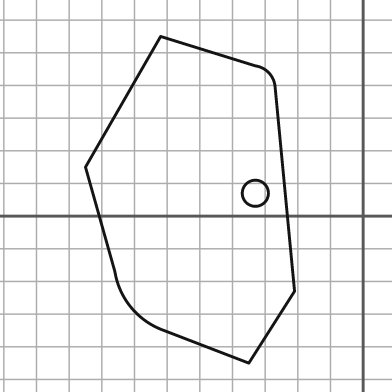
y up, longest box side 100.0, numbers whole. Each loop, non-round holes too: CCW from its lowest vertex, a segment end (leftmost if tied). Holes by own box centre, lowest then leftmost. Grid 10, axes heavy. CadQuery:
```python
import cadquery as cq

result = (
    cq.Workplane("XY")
    .moveTo(-35.0, -45.0)
    .lineTo(-21.0, -23.0)
    .lineTo(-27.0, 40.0)
    .threePointArc((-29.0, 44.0), (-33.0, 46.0))
    .lineTo(-62.0, 55.0)
    .lineTo(-85.0, 15.0)
    .lineTo(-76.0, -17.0)
    .threePointArc((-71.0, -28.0), (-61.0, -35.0))
    .close()
    .moveTo(-33.0, 7.0)
    .circle(4.0)
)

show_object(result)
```